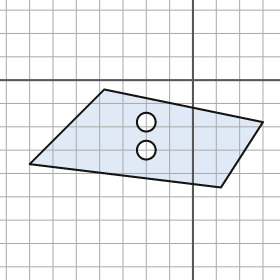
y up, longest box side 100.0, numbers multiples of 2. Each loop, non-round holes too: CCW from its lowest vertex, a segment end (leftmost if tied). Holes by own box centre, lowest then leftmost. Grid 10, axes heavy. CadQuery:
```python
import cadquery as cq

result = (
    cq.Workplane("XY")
    .moveTo(12.0, -46.0)
    .lineTo(30.0, -18.0)
    .lineTo(-38.0, -4.0)
    .lineTo(-70.0, -36.0)
    .close()
    .moveTo(-20.0, -30.0)
    .circle(4.0)
    .moveTo(-20.0, -18.0)
    .circle(4.0)
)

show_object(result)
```